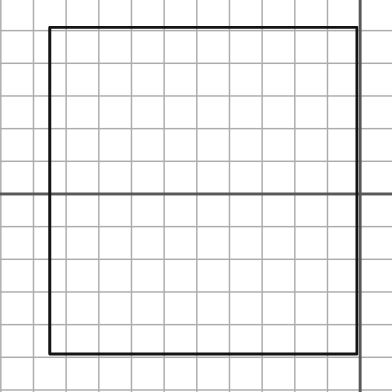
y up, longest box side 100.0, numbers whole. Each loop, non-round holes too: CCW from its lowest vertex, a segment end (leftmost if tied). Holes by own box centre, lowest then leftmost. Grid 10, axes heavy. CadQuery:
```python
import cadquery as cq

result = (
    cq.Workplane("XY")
    .moveTo(-95.0, -49.0)
    .lineTo(-1.0, -49.0)
    .lineTo(-1.0, 51.0)
    .lineTo(-95.0, 51.0)
    .close()
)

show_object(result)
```